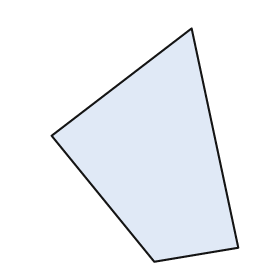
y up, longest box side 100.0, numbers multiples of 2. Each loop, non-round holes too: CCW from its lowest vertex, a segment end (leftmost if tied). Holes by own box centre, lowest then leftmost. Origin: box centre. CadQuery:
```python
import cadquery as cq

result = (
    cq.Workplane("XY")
    .moveTo(4.0, -50.0)
    .lineTo(40.0, -44.0)
    .lineTo(20.0, 50.0)
    .lineTo(-40.0, 4.0)
    .close()
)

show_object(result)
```